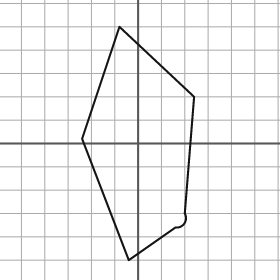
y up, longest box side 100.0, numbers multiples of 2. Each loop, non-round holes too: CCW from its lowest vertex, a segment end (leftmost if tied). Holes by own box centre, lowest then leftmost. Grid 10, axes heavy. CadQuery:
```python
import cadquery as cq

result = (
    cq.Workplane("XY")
    .moveTo(-4.0, -50.0)
    .lineTo(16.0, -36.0)
    .threePointArc((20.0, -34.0), (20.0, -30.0))
    .lineTo(24.0, 20.0)
    .lineTo(-8.0, 50.0)
    .lineTo(-24.0, 2.0)
    .close()
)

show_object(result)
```